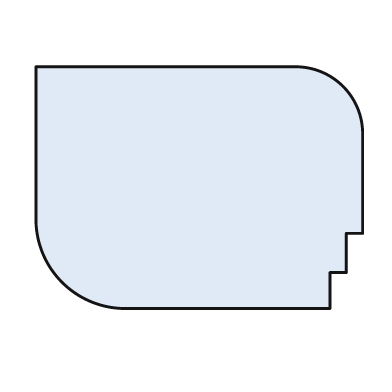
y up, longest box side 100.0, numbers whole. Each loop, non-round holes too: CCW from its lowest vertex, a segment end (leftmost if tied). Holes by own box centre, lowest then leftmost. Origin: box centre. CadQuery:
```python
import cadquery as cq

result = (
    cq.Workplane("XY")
    .moveTo(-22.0, -37.0)
    .lineTo(40.0, -37.0)
    .lineTo(40.0, -26.0)
    .lineTo(45.0, -26.0)
    .lineTo(45.0, -14.0)
    .lineTo(50.0, -14.0)
    .lineTo(50.0, 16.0)
    .threePointArc((44.0, 31.0), (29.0, 37.0))
    .lineTo(-50.0, 37.0)
    .lineTo(-50.0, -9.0)
    .threePointArc((-42.0, -29.0), (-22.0, -37.0))
    .close()
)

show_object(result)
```